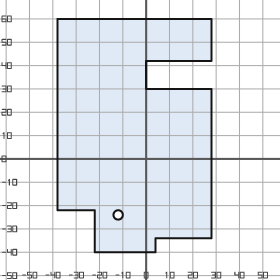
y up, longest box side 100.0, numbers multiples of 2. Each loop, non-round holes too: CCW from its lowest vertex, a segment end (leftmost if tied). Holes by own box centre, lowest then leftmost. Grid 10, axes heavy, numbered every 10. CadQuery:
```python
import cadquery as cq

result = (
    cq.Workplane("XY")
    .moveTo(-22.0, -40.0)
    .lineTo(4.0, -40.0)
    .lineTo(4.0, -34.0)
    .lineTo(28.0, -34.0)
    .lineTo(28.0, 30.0)
    .lineTo(0.0, 30.0)
    .lineTo(0.0, 42.0)
    .lineTo(28.0, 42.0)
    .lineTo(28.0, 60.0)
    .lineTo(-38.0, 60.0)
    .lineTo(-38.0, -22.0)
    .lineTo(-22.0, -22.0)
    .close()
    .moveTo(-12.0, -24.0)
    .circle(2.0)
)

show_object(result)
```